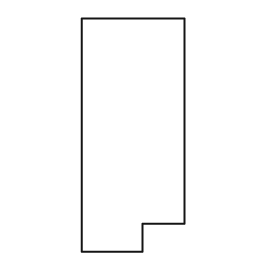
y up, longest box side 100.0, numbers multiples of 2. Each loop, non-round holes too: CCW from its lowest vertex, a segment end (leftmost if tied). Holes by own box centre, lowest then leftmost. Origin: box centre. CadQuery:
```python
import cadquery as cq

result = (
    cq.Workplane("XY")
    .moveTo(-22.0, -50.0)
    .lineTo(4.0, -50.0)
    .lineTo(4.0, -38.0)
    .lineTo(22.0, -38.0)
    .lineTo(22.0, 50.0)
    .lineTo(-22.0, 50.0)
    .close()
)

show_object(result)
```